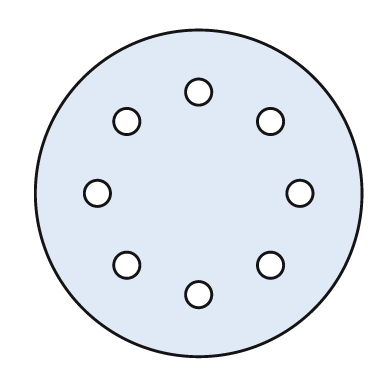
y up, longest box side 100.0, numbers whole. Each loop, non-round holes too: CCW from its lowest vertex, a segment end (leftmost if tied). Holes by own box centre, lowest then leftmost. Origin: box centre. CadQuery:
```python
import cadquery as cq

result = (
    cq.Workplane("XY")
    .moveTo(0.0, 0.0)
    .circle(50.0)
    .moveTo(0.0, -31.0)
    .circle(4.0)
    .moveTo(-22.0, -22.0)
    .circle(4.0)
    .moveTo(22.0, -22.0)
    .circle(4.0)
    .moveTo(-31.0, 0.0)
    .circle(4.0)
    .moveTo(31.0, 0.0)
    .circle(4.0)
    .moveTo(-22.0, 22.0)
    .circle(4.0)
    .moveTo(22.0, 22.0)
    .circle(4.0)
    .moveTo(0.0, 31.0)
    .circle(4.0)
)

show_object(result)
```